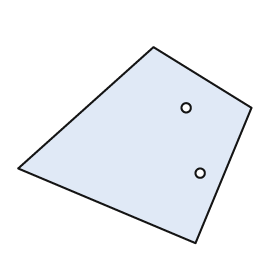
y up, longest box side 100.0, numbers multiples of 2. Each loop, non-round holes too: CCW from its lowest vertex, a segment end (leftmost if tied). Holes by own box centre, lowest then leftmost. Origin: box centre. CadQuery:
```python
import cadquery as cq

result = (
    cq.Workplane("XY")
    .moveTo(26.0, -42.0)
    .lineTo(50.0, 16.0)
    .lineTo(8.0, 42.0)
    .lineTo(-50.0, -10.0)
    .close()
    .moveTo(28.0, -12.0)
    .circle(2.0)
    .moveTo(22.0, 16.0)
    .circle(2.0)
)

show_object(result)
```